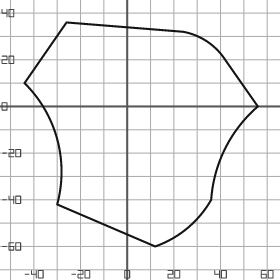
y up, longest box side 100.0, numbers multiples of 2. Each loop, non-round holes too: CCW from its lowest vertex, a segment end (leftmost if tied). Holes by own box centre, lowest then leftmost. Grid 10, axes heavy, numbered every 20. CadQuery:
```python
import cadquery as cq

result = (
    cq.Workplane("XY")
    .moveTo(12.0, -60.0)
    .threePointArc((26.0, -52.0), (36.0, -40.0))
    .threePointArc((42.0, -18.0), (56.0, 0.0))
    .lineTo(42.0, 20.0)
    .threePointArc((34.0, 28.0), (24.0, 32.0))
    .lineTo(-26.0, 36.0)
    .lineTo(-44.0, 10.0)
    .threePointArc((-30.0, -14.0), (-30.0, -42.0))
    .close()
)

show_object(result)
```